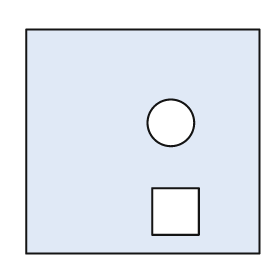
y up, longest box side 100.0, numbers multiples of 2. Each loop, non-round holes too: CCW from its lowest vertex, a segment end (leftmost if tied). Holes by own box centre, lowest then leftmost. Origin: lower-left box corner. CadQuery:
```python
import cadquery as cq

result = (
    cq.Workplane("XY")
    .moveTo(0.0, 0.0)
    .lineTo(100.0, 0.0)
    .lineTo(100.0, 96.0)
    .lineTo(0.0, 96.0)
    .close()
    .moveTo(54.0, 8.0)
    .lineTo(74.0, 8.0)
    .lineTo(74.0, 28.0)
    .lineTo(54.0, 28.0)
    .close()
    .moveTo(62.0, 56.0)
    .circle(10.0)
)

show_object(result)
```